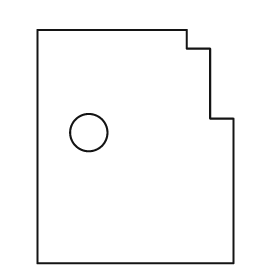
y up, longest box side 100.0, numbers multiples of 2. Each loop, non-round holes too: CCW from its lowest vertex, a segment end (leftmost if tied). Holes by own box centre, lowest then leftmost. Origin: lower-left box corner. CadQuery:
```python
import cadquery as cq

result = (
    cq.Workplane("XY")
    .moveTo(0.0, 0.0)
    .lineTo(84.0, 0.0)
    .lineTo(84.0, 62.0)
    .lineTo(74.0, 62.0)
    .lineTo(74.0, 92.0)
    .lineTo(64.0, 92.0)
    .lineTo(64.0, 100.0)
    .lineTo(0.0, 100.0)
    .close()
    .moveTo(22.0, 56.0)
    .circle(8.0)
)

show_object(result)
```